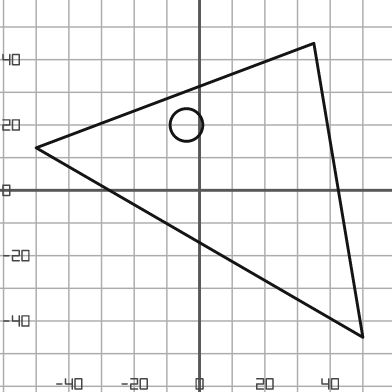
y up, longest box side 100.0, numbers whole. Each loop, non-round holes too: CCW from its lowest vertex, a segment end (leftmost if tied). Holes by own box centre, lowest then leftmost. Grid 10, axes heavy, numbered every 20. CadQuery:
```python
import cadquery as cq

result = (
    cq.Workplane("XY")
    .moveTo(50.0, -45.0)
    .lineTo(35.0, 45.0)
    .lineTo(-50.0, 13.0)
    .close()
    .moveTo(-4.0, 20.0)
    .circle(5.0)
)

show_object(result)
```